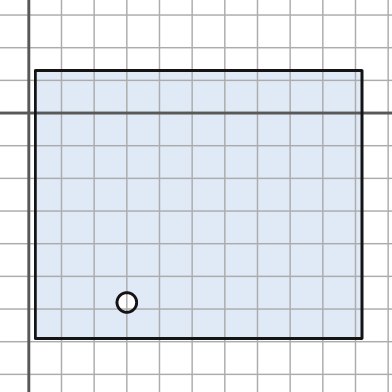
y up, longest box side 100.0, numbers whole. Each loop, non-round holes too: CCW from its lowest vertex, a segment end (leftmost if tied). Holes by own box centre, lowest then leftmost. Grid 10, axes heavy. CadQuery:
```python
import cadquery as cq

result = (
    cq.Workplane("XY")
    .moveTo(2.0, -69.0)
    .lineTo(102.0, -69.0)
    .lineTo(102.0, 13.0)
    .lineTo(2.0, 13.0)
    .close()
    .moveTo(30.0, -58.0)
    .circle(3.0)
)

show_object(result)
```